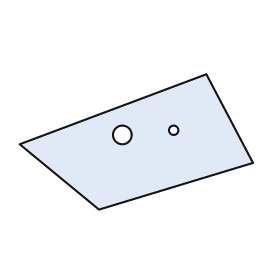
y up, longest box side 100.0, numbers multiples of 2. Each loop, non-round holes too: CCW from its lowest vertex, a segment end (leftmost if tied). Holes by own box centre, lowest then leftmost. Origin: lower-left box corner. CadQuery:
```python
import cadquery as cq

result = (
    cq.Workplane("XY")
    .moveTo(34.0, 0.0)
    .lineTo(100.0, 20.0)
    .lineTo(80.0, 58.0)
    .lineTo(0.0, 28.0)
    .close()
    .moveTo(44.0, 32.0)
    .circle(4.0)
    .moveTo(66.0, 34.0)
    .circle(2.0)
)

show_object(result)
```